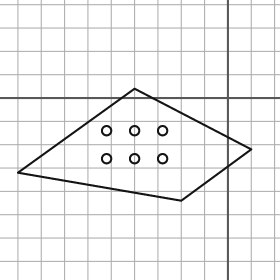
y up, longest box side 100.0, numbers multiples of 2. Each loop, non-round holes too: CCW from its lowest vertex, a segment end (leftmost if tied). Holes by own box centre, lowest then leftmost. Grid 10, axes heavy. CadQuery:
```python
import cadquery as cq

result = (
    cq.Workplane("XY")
    .moveTo(-20.0, -44.0)
    .lineTo(10.0, -22.0)
    .lineTo(-40.0, 4.0)
    .lineTo(-90.0, -32.0)
    .close()
    .moveTo(-52.0, -26.0)
    .circle(2.0)
    .moveTo(-40.0, -26.0)
    .circle(2.0)
    .moveTo(-28.0, -26.0)
    .circle(2.0)
    .moveTo(-52.0, -14.0)
    .circle(2.0)
    .moveTo(-40.0, -14.0)
    .circle(2.0)
    .moveTo(-28.0, -14.0)
    .circle(2.0)
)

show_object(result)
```